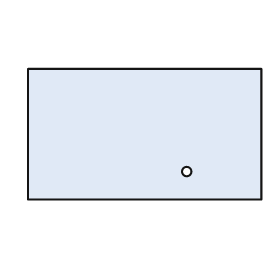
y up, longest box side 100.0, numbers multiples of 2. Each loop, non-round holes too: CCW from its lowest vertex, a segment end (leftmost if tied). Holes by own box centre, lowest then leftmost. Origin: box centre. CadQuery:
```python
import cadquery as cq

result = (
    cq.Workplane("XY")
    .moveTo(-50.0, -28.0)
    .lineTo(50.0, -28.0)
    .lineTo(50.0, 28.0)
    .lineTo(-50.0, 28.0)
    .close()
    .moveTo(18.0, -16.0)
    .circle(2.0)
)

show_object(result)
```